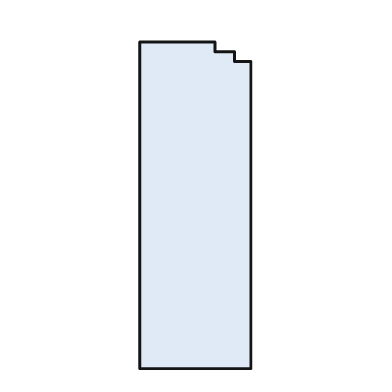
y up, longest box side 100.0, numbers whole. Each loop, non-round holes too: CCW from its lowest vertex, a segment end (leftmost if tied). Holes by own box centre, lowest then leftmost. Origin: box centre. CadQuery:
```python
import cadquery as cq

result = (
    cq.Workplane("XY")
    .moveTo(-17.0, -50.0)
    .lineTo(17.0, -50.0)
    .lineTo(17.0, 44.0)
    .lineTo(12.0, 44.0)
    .lineTo(12.0, 47.0)
    .lineTo(6.0, 47.0)
    .lineTo(6.0, 50.0)
    .lineTo(-17.0, 50.0)
    .close()
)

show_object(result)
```